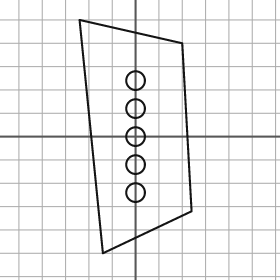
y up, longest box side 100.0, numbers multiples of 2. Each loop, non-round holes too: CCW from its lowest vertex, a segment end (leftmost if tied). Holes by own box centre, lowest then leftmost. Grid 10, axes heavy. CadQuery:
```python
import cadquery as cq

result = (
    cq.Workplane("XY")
    .moveTo(-14.0, -50.0)
    .lineTo(24.0, -32.0)
    .lineTo(20.0, 40.0)
    .lineTo(-24.0, 50.0)
    .close()
    .moveTo(0.0, -24.0)
    .circle(4.0)
    .moveTo(0.0, -12.0)
    .circle(4.0)
    .moveTo(0.0, 0.0)
    .circle(4.0)
    .moveTo(0.0, 12.0)
    .circle(4.0)
    .moveTo(0.0, 24.0)
    .circle(4.0)
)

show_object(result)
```